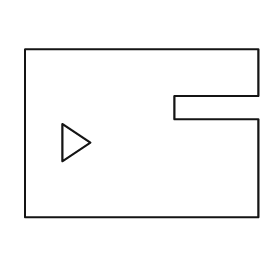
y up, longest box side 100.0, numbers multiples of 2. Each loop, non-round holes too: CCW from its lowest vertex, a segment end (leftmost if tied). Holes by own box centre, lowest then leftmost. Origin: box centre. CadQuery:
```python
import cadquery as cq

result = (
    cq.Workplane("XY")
    .moveTo(-50.0, -36.0)
    .lineTo(50.0, -36.0)
    .lineTo(50.0, 6.0)
    .lineTo(14.0, 6.0)
    .lineTo(14.0, 16.0)
    .lineTo(50.0, 16.0)
    .lineTo(50.0, 36.0)
    .lineTo(-50.0, 36.0)
    .close()
    .moveTo(-34.0, -12.0)
    .lineTo(-22.0, -4.0)
    .lineTo(-34.0, 4.0)
    .close()
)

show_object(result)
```